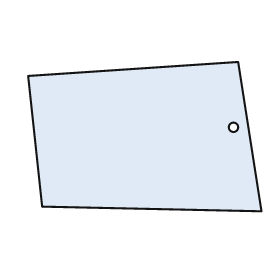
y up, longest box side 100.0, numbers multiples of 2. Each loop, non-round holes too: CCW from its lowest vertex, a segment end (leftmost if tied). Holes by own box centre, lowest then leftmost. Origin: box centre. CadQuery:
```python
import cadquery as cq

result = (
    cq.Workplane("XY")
    .moveTo(50.0, -32.0)
    .lineTo(40.0, 32.0)
    .lineTo(-50.0, 26.0)
    .lineTo(-44.0, -30.0)
    .close()
    .moveTo(38.0, 4.0)
    .circle(2.0)
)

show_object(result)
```